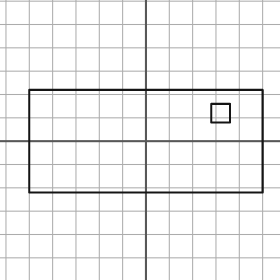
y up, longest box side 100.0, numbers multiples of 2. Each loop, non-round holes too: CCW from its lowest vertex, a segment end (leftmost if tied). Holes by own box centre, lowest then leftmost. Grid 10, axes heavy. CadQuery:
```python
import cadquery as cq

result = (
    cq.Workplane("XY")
    .moveTo(-50.0, -22.0)
    .lineTo(50.0, -22.0)
    .lineTo(50.0, 22.0)
    .lineTo(-50.0, 22.0)
    .close()
    .moveTo(28.0, 8.0)
    .lineTo(36.0, 8.0)
    .lineTo(36.0, 16.0)
    .lineTo(28.0, 16.0)
    .close()
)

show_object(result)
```